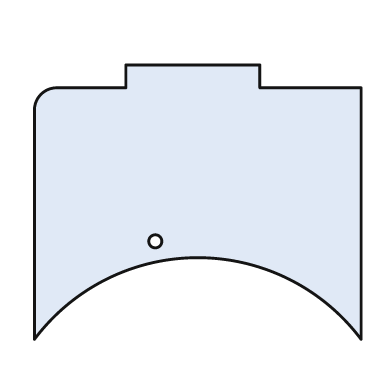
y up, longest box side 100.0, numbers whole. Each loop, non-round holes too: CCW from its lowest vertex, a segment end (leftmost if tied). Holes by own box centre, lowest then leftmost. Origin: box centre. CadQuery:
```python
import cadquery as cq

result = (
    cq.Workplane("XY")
    .moveTo(-50.0, -42.0)
    .threePointArc((0.0, -17.0), (50.0, -42.0))
    .lineTo(50.0, 35.0)
    .lineTo(19.0, 35.0)
    .lineTo(19.0, 42.0)
    .lineTo(-22.0, 42.0)
    .lineTo(-22.0, 35.0)
    .lineTo(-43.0, 35.0)
    .threePointArc((-48.0, 33.0), (-50.0, 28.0))
    .close()
    .moveTo(-13.0, -12.0)
    .circle(2.0)
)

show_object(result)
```